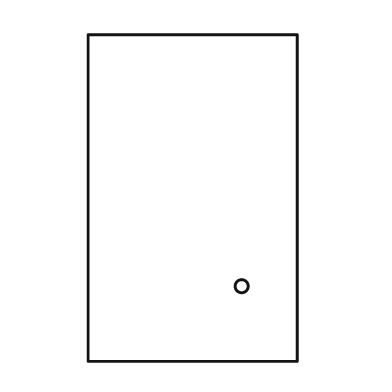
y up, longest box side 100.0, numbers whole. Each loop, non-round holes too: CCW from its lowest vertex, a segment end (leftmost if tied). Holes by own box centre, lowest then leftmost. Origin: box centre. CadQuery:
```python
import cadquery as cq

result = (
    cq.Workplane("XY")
    .moveTo(-32.0, -50.0)
    .lineTo(32.0, -50.0)
    .lineTo(32.0, 50.0)
    .lineTo(-32.0, 50.0)
    .close()
    .moveTo(15.0, -27.0)
    .circle(2.0)
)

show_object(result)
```